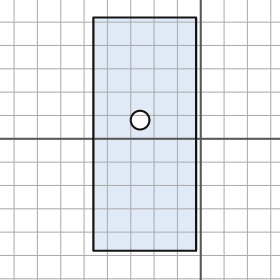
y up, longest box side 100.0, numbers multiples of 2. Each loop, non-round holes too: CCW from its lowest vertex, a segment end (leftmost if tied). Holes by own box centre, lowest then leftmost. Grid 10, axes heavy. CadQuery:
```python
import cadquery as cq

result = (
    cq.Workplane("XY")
    .moveTo(-46.0, -48.0)
    .lineTo(-2.0, -48.0)
    .lineTo(-2.0, 52.0)
    .lineTo(-46.0, 52.0)
    .close()
    .moveTo(-26.0, 8.0)
    .circle(4.0)
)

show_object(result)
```